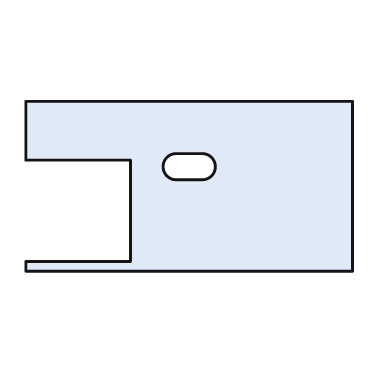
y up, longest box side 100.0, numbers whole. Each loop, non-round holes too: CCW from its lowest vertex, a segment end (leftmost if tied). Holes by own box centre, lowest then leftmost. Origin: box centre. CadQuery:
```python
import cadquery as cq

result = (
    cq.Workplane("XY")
    .moveTo(-50.0, -26.0)
    .lineTo(50.0, -26.0)
    .lineTo(50.0, 26.0)
    .lineTo(-50.0, 26.0)
    .lineTo(-50.0, 8.0)
    .lineTo(-18.0, 8.0)
    .lineTo(-18.0, -23.0)
    .lineTo(-50.0, -23.0)
    .close()
    .moveTo(-4.0, 2.0)
    .lineTo(4.0, 2.0)
    .threePointArc((8.0, 6.0), (4.0, 10.0))
    .lineTo(-4.0, 10.0)
    .threePointArc((-8.0, 6.0), (-4.0, 2.0))
    .close()
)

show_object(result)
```